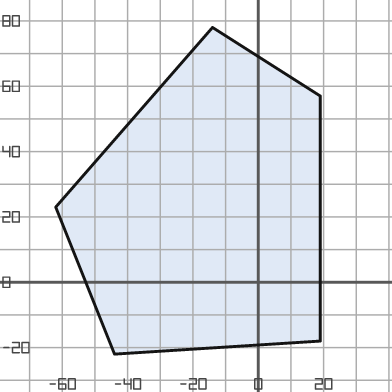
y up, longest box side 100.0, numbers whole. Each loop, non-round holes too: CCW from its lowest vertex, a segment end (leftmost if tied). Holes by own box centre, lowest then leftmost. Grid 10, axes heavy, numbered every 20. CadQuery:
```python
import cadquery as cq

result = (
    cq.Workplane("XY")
    .moveTo(-44.0, -22.0)
    .lineTo(19.0, -18.0)
    .lineTo(19.0, 57.0)
    .lineTo(-14.0, 78.0)
    .lineTo(-62.0, 23.0)
    .close()
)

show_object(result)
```